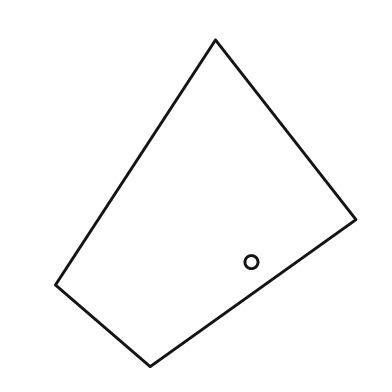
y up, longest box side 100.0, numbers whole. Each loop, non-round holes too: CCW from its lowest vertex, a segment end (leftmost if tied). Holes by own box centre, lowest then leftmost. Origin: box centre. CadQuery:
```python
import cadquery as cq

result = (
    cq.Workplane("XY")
    .moveTo(-17.0, -50.0)
    .lineTo(46.0, -5.0)
    .lineTo(3.0, 50.0)
    .lineTo(-46.0, -25.0)
    .close()
    .moveTo(14.0, -18.0)
    .circle(2.0)
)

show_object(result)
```